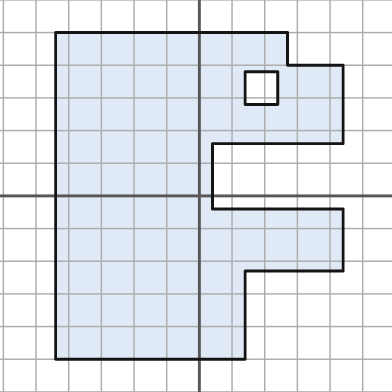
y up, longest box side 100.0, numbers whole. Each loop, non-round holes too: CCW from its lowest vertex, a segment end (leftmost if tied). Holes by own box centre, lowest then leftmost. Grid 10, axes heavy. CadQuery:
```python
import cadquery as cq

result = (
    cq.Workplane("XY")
    .moveTo(-44.0, -50.0)
    .lineTo(14.0, -50.0)
    .lineTo(14.0, -23.0)
    .lineTo(44.0, -23.0)
    .lineTo(44.0, -4.0)
    .lineTo(4.0, -4.0)
    .lineTo(4.0, 16.0)
    .lineTo(44.0, 16.0)
    .lineTo(44.0, 40.0)
    .lineTo(27.0, 40.0)
    .lineTo(27.0, 50.0)
    .lineTo(-44.0, 50.0)
    .close()
    .moveTo(14.0, 28.0)
    .lineTo(24.0, 28.0)
    .lineTo(24.0, 38.0)
    .lineTo(14.0, 38.0)
    .close()
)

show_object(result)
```